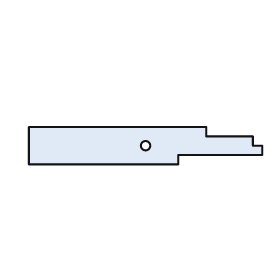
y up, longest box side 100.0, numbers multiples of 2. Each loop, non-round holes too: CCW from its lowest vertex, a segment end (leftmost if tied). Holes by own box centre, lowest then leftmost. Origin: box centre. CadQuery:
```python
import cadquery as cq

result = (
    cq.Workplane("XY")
    .moveTo(-50.0, -8.0)
    .lineTo(14.0, -8.0)
    .lineTo(14.0, -4.0)
    .lineTo(50.0, -4.0)
    .lineTo(50.0, 0.0)
    .lineTo(46.0, 0.0)
    .lineTo(46.0, 4.0)
    .lineTo(26.0, 4.0)
    .lineTo(26.0, 8.0)
    .lineTo(-50.0, 8.0)
    .close()
    .moveTo(0.0, 0.0)
    .circle(2.0)
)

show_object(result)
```